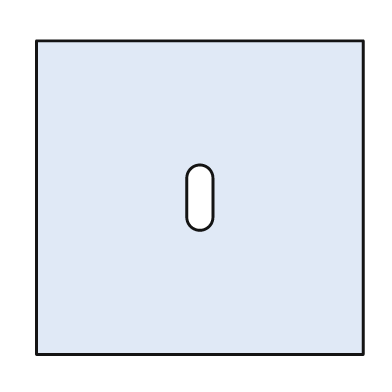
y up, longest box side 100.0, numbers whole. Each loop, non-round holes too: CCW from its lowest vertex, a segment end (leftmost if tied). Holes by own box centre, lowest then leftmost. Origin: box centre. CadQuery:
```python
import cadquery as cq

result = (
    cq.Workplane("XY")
    .moveTo(-50.0, -48.0)
    .lineTo(50.0, -48.0)
    .lineTo(50.0, 48.0)
    .lineTo(-50.0, 48.0)
    .close()
    .moveTo(-4.0, -6.0)
    .threePointArc((0.0, -10.0), (4.0, -6.0))
    .lineTo(4.0, 6.0)
    .threePointArc((0.0, 10.0), (-4.0, 6.0))
    .close()
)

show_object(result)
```